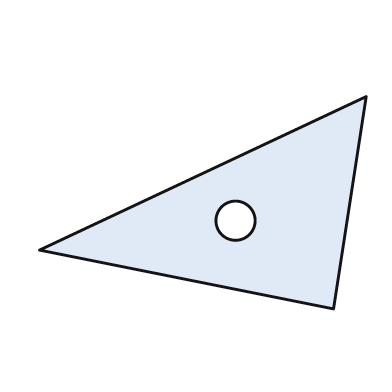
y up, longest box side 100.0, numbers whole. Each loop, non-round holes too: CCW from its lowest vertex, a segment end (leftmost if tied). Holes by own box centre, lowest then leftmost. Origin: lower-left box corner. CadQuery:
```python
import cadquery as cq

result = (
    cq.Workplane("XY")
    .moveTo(90.0, 0.0)
    .lineTo(100.0, 65.0)
    .lineTo(0.0, 18.0)
    .close()
    .moveTo(60.0, 27.0)
    .circle(6.0)
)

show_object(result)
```